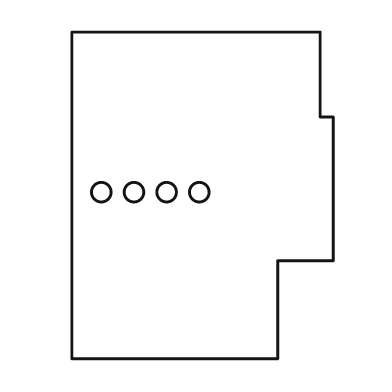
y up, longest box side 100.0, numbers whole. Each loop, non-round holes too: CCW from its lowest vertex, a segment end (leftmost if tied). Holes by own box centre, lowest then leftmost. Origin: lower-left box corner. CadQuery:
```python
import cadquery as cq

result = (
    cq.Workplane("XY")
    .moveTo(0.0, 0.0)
    .lineTo(63.0, 0.0)
    .lineTo(63.0, 30.0)
    .lineTo(80.0, 30.0)
    .lineTo(80.0, 74.0)
    .lineTo(76.0, 74.0)
    .lineTo(76.0, 100.0)
    .lineTo(0.0, 100.0)
    .close()
    .moveTo(9.0, 51.0)
    .circle(3.0)
    .moveTo(19.0, 51.0)
    .circle(3.0)
    .moveTo(29.0, 51.0)
    .circle(3.0)
    .moveTo(39.0, 51.0)
    .circle(3.0)
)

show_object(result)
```